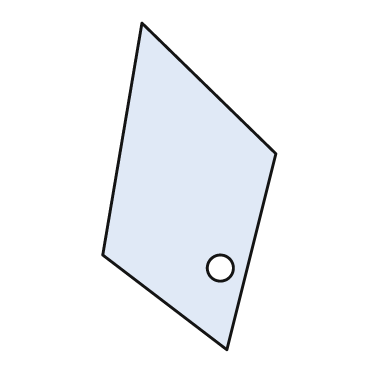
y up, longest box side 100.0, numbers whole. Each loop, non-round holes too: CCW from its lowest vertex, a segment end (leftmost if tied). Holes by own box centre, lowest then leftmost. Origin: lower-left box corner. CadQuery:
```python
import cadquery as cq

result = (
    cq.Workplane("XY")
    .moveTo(38.0, 0.0)
    .lineTo(53.0, 60.0)
    .lineTo(12.0, 100.0)
    .lineTo(0.0, 29.0)
    .close()
    .moveTo(36.0, 25.0)
    .circle(4.0)
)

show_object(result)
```